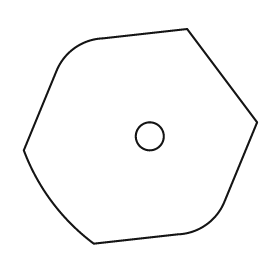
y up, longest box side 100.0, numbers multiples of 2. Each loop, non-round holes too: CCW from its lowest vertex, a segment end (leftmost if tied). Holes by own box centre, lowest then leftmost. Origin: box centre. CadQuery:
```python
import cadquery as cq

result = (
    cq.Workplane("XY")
    .moveTo(-20.0, -46.0)
    .lineTo(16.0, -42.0)
    .threePointArc((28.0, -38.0), (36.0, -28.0))
    .lineTo(50.0, 6.0)
    .lineTo(20.0, 46.0)
    .lineTo(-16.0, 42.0)
    .threePointArc((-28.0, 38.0), (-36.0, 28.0))
    .lineTo(-50.0, -6.0)
    .threePointArc((-38.0, -28.0), (-20.0, -46.0))
    .close()
    .moveTo(4.0, 0.0)
    .circle(6.0)
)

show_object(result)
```